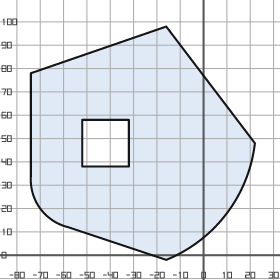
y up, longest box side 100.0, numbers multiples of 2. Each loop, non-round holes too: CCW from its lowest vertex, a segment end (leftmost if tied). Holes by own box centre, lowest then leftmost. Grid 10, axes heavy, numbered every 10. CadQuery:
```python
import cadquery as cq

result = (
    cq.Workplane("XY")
    .moveTo(-16.0, -2.0)
    .threePointArc((10.0, 18.0), (22.0, 48.0))
    .lineTo(-16.0, 98.0)
    .lineTo(-74.0, 78.0)
    .lineTo(-74.0, 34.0)
    .threePointArc((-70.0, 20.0), (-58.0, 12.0))
    .close()
    .moveTo(-52.0, 38.0)
    .lineTo(-32.0, 38.0)
    .lineTo(-32.0, 58.0)
    .lineTo(-52.0, 58.0)
    .close()
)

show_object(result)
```